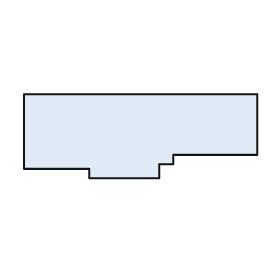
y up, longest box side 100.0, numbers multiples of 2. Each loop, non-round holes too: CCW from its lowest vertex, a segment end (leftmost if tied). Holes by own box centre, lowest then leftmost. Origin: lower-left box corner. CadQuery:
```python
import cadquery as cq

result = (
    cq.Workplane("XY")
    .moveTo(28.0, 0.0)
    .lineTo(58.0, 0.0)
    .lineTo(58.0, 6.0)
    .lineTo(64.0, 6.0)
    .lineTo(64.0, 10.0)
    .lineTo(100.0, 10.0)
    .lineTo(100.0, 36.0)
    .lineTo(0.0, 36.0)
    .lineTo(0.0, 4.0)
    .lineTo(28.0, 4.0)
    .close()
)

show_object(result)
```